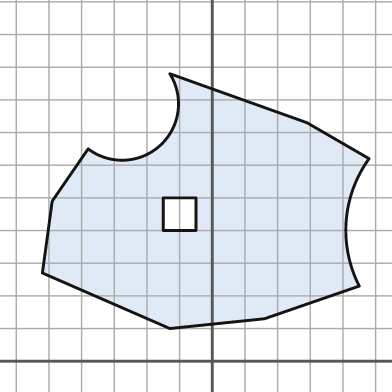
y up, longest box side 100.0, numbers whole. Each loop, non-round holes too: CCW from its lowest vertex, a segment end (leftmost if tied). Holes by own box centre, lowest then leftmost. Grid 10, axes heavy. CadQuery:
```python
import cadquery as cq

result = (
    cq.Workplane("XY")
    .moveTo(-13.0, 10.0)
    .lineTo(16.0, 13.0)
    .lineTo(45.0, 23.0)
    .threePointArc((41.0, 43.0), (48.0, 62.0))
    .lineTo(29.0, 73.0)
    .lineTo(-13.0, 88.0)
    .threePointArc((-16.0, 66.0), (-38.0, 65.0))
    .lineTo(-49.0, 49.0)
    .lineTo(-52.0, 27.0)
    .close()
    .moveTo(-15.0, 40.0)
    .lineTo(-5.0, 40.0)
    .lineTo(-5.0, 50.0)
    .lineTo(-15.0, 50.0)
    .close()
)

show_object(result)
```